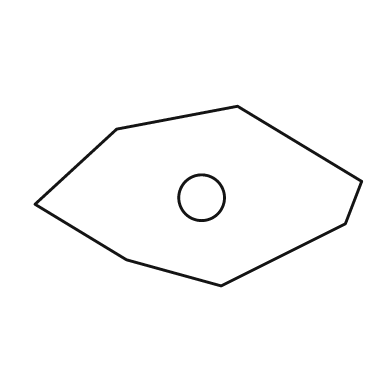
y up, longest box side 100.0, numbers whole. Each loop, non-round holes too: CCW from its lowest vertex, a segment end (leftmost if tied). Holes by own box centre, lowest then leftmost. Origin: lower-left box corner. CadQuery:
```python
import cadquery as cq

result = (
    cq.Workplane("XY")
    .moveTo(57.0, 0.0)
    .lineTo(95.0, 19.0)
    .lineTo(100.0, 32.0)
    .lineTo(62.0, 55.0)
    .lineTo(25.0, 48.0)
    .lineTo(0.0, 25.0)
    .lineTo(28.0, 8.0)
    .close()
    .moveTo(51.0, 27.0)
    .circle(7.0)
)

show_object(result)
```